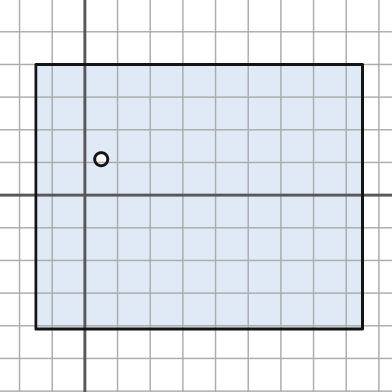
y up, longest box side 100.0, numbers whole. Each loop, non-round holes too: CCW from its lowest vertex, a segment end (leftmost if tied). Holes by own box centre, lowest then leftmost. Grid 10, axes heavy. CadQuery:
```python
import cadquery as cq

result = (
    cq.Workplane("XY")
    .moveTo(-15.0, -41.0)
    .lineTo(85.0, -41.0)
    .lineTo(85.0, 40.0)
    .lineTo(-15.0, 40.0)
    .close()
    .moveTo(5.0, 11.0)
    .circle(2.0)
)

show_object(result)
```